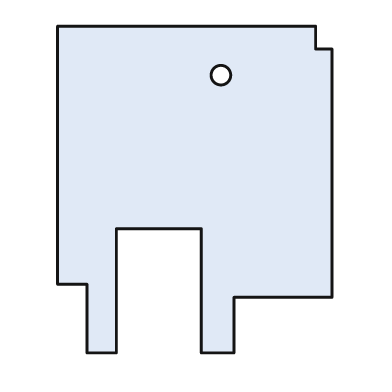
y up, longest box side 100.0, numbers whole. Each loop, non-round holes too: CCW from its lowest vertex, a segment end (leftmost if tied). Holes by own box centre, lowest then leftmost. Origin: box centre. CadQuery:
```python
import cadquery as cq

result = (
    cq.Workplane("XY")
    .moveTo(-33.0, -50.0)
    .lineTo(-24.0, -50.0)
    .lineTo(-24.0, -12.0)
    .lineTo(2.0, -12.0)
    .lineTo(2.0, -50.0)
    .lineTo(12.0, -50.0)
    .lineTo(12.0, -33.0)
    .lineTo(42.0, -33.0)
    .lineTo(42.0, 43.0)
    .lineTo(37.0, 43.0)
    .lineTo(37.0, 50.0)
    .lineTo(-42.0, 50.0)
    .lineTo(-42.0, -29.0)
    .lineTo(-33.0, -29.0)
    .close()
    .moveTo(8.0, 35.0)
    .circle(3.0)
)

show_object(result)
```